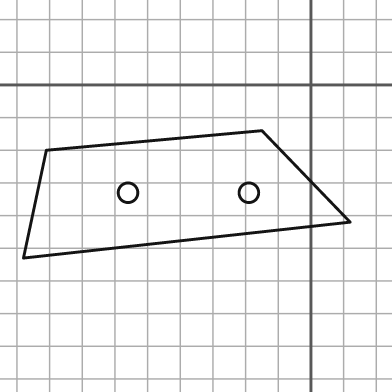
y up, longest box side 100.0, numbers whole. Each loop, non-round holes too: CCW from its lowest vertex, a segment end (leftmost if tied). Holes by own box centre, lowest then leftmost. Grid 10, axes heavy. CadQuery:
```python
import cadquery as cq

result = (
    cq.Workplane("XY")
    .moveTo(-88.0, -53.0)
    .lineTo(12.0, -42.0)
    .lineTo(-15.0, -14.0)
    .lineTo(-81.0, -20.0)
    .close()
    .moveTo(-56.0, -33.0)
    .circle(3.0)
    .moveTo(-19.0, -33.0)
    .circle(3.0)
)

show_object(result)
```